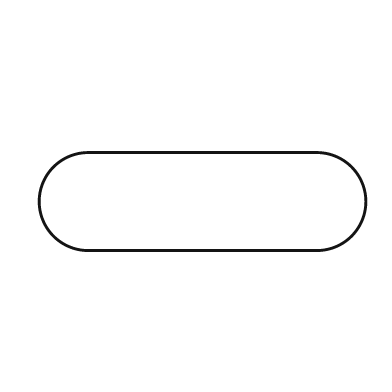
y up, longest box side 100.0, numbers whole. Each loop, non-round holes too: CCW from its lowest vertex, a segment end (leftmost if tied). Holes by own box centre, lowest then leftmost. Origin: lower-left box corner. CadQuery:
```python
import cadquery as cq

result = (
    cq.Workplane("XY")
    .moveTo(15.0, 0.0)
    .lineTo(85.0, 0.0)
    .threePointArc((100.0, 15.0), (85.0, 30.0))
    .lineTo(15.0, 30.0)
    .threePointArc((0.0, 15.0), (15.0, 0.0))
    .close()
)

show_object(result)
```